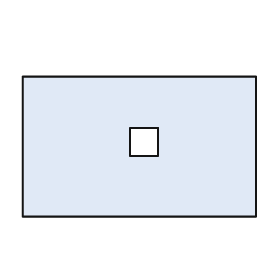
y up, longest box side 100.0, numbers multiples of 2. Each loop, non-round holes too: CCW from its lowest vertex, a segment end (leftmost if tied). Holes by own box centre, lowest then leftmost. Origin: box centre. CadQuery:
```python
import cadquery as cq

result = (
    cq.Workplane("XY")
    .moveTo(-50.0, -30.0)
    .lineTo(50.0, -30.0)
    .lineTo(50.0, 30.0)
    .lineTo(-50.0, 30.0)
    .close()
    .moveTo(-4.0, -4.0)
    .lineTo(8.0, -4.0)
    .lineTo(8.0, 8.0)
    .lineTo(-4.0, 8.0)
    .close()
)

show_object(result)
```